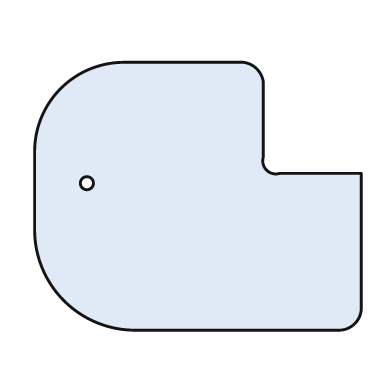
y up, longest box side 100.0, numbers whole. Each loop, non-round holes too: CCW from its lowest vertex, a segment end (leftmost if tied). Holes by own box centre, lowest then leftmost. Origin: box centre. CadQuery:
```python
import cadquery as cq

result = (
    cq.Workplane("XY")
    .moveTo(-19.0, -41.0)
    .lineTo(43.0, -41.0)
    .threePointArc((48.0, -39.0), (50.0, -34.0))
    .lineTo(50.0, 7.0)
    .lineTo(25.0, 7.0)
    .threePointArc((21.0, 8.0), (20.0, 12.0))
    .lineTo(20.0, 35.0)
    .threePointArc((18.0, 39.0), (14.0, 41.0))
    .lineTo(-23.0, 41.0)
    .threePointArc((-42.0, 33.0), (-50.0, 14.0))
    .lineTo(-50.0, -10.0)
    .threePointArc((-41.0, -32.0), (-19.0, -41.0))
    .close()
    .moveTo(-34.0, 4.0)
    .circle(2.0)
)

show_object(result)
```